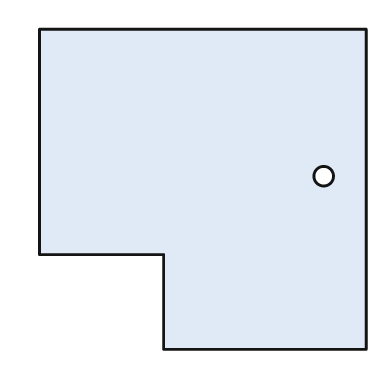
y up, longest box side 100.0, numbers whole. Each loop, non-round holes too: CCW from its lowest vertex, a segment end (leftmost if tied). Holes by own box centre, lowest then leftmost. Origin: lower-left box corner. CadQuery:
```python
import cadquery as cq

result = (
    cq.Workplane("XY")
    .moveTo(38.0, 0.0)
    .lineTo(100.0, 0.0)
    .lineTo(100.0, 98.0)
    .lineTo(0.0, 98.0)
    .lineTo(0.0, 29.0)
    .lineTo(38.0, 29.0)
    .close()
    .moveTo(87.0, 53.0)
    .circle(3.0)
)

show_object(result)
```